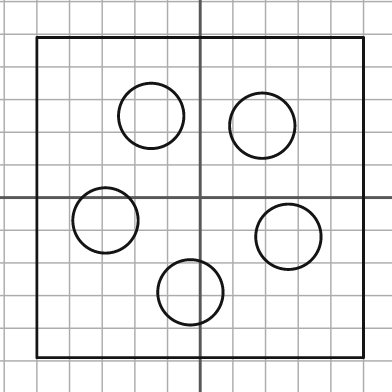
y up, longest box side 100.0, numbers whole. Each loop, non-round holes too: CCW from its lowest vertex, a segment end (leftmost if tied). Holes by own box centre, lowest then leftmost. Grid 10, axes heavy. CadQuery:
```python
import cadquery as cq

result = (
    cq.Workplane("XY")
    .moveTo(-50.0, -49.0)
    .lineTo(50.0, -49.0)
    .lineTo(50.0, 49.0)
    .lineTo(-50.0, 49.0)
    .close()
    .moveTo(-3.0, -29.0)
    .circle(10.0)
    .moveTo(27.0, -12.0)
    .circle(10.0)
    .moveTo(-29.0, -7.0)
    .circle(10.0)
    .moveTo(19.0, 22.0)
    .circle(10.0)
    .moveTo(-15.0, 25.0)
    .circle(10.0)
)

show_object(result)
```